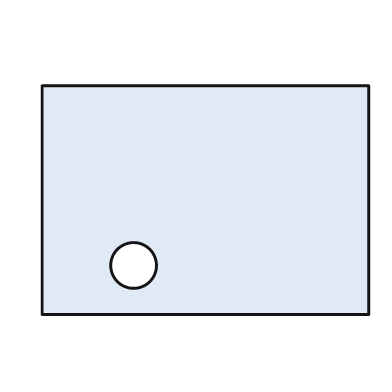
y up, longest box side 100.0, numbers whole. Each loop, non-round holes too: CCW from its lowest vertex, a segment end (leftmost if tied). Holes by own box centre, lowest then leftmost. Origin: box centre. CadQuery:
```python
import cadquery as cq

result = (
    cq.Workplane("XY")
    .moveTo(-50.0, -35.0)
    .lineTo(50.0, -35.0)
    .lineTo(50.0, 35.0)
    .lineTo(-50.0, 35.0)
    .close()
    .moveTo(-22.0, -20.0)
    .circle(7.0)
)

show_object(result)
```